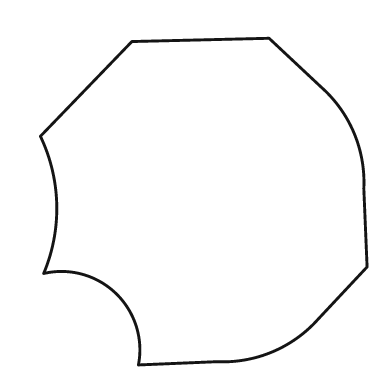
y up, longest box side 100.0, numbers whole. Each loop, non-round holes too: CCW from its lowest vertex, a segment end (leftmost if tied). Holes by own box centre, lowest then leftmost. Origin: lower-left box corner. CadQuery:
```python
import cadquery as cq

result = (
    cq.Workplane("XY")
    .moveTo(30.0, 0.0)
    .lineTo(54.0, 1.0)
    .threePointArc((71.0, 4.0), (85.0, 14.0))
    .lineTo(100.0, 30.0)
    .lineTo(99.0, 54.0)
    .threePointArc((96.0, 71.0), (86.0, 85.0))
    .lineTo(70.0, 100.0)
    .lineTo(28.0, 99.0)
    .lineTo(0.0, 70.0)
    .threePointArc((5.0, 49.0), (1.0, 28.0))
    .threePointArc((23.0, 22.0), (30.0, 0.0))
    .close()
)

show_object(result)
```